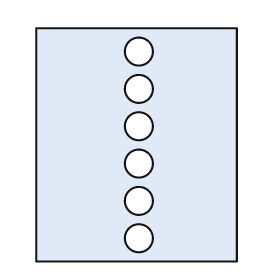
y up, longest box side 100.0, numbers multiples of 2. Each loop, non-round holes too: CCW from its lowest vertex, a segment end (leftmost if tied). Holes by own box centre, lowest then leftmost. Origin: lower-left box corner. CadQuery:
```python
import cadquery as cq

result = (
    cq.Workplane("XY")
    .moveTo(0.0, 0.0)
    .lineTo(86.0, 0.0)
    .lineTo(86.0, 100.0)
    .lineTo(0.0, 100.0)
    .close()
    .moveTo(44.0, 10.0)
    .circle(6.0)
    .moveTo(44.0, 26.0)
    .circle(6.0)
    .moveTo(44.0, 42.0)
    .circle(6.0)
    .moveTo(44.0, 58.0)
    .circle(6.0)
    .moveTo(44.0, 74.0)
    .circle(6.0)
    .moveTo(44.0, 90.0)
    .circle(6.0)
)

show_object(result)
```